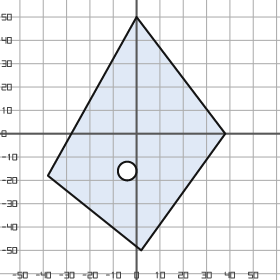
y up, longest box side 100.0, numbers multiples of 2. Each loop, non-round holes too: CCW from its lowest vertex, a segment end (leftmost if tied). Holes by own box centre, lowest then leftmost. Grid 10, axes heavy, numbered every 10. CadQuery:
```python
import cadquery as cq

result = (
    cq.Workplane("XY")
    .moveTo(2.0, -50.0)
    .lineTo(38.0, 0.0)
    .lineTo(0.0, 50.0)
    .lineTo(-38.0, -18.0)
    .close()
    .moveTo(-4.0, -16.0)
    .circle(4.0)
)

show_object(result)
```